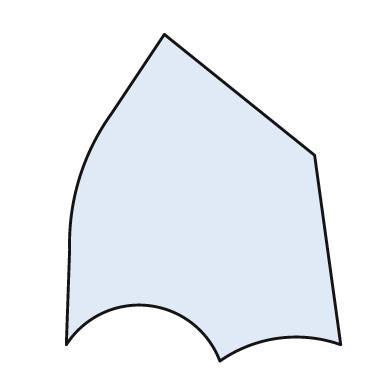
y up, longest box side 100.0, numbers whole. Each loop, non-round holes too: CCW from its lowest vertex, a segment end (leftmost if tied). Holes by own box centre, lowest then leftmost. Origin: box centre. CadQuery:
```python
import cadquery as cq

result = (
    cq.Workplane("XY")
    .moveTo(5.0, -50.0)
    .threePointArc((23.0, -43.0), (42.0, -45.0))
    .lineTo(34.0, 13.0)
    .lineTo(-12.0, 50.0)
    .lineTo(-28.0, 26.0)
    .threePointArc((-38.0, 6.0), (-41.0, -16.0))
    .lineTo(-42.0, -45.0)
    .threePointArc((-17.0, -33.0), (5.0, -50.0))
    .close()
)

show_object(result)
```